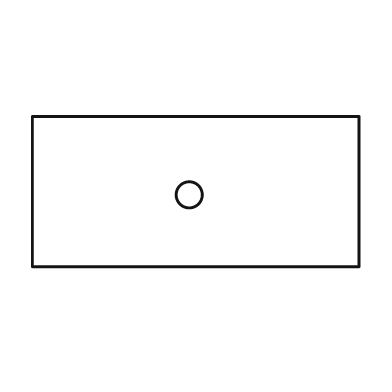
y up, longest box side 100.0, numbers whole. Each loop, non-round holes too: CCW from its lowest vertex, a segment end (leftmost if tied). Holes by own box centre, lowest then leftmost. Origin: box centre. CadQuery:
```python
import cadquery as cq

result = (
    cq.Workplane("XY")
    .moveTo(-50.0, -23.0)
    .lineTo(50.0, -23.0)
    .lineTo(50.0, 23.0)
    .lineTo(-50.0, 23.0)
    .close()
    .moveTo(-2.0, -1.0)
    .circle(4.0)
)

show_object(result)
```